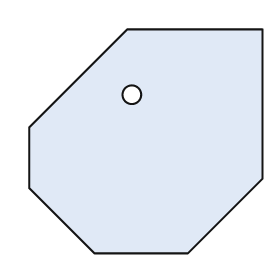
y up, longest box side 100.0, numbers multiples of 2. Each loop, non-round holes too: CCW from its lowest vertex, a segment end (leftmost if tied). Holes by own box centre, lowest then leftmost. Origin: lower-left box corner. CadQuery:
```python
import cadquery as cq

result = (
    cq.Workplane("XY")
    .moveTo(28.0, 0.0)
    .lineTo(68.0, 0.0)
    .lineTo(100.0, 32.0)
    .lineTo(100.0, 96.0)
    .lineTo(42.0, 96.0)
    .lineTo(0.0, 54.0)
    .lineTo(0.0, 28.0)
    .close()
    .moveTo(44.0, 68.0)
    .circle(4.0)
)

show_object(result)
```